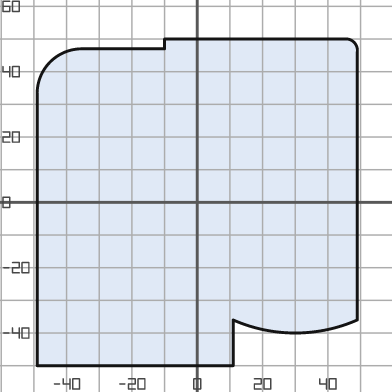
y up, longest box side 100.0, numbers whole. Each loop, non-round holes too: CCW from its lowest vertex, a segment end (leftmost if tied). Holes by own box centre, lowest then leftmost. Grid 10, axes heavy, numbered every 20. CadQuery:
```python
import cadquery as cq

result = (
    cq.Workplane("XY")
    .moveTo(-49.0, -50.0)
    .lineTo(11.0, -50.0)
    .lineTo(11.0, -36.0)
    .threePointArc((30.0, -40.0), (49.0, -36.0))
    .lineTo(49.0, 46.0)
    .threePointArc((48.0, 49.0), (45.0, 50.0))
    .lineTo(-10.0, 50.0)
    .lineTo(-10.0, 47.0)
    .lineTo(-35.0, 47.0)
    .threePointArc((-45.0, 43.0), (-49.0, 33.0))
    .close()
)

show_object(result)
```